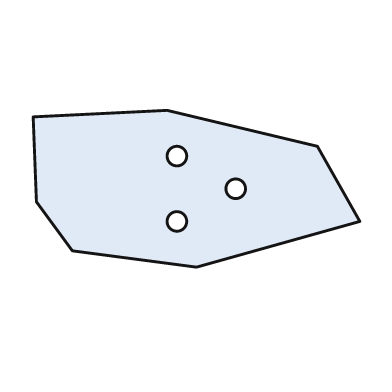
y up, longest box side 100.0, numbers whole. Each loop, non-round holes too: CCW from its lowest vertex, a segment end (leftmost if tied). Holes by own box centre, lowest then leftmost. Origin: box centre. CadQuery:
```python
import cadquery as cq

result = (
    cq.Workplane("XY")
    .moveTo(0.0, -24.0)
    .lineTo(50.0, -10.0)
    .lineTo(37.0, 13.0)
    .lineTo(-9.0, 24.0)
    .lineTo(-50.0, 22.0)
    .lineTo(-49.0, -4.0)
    .lineTo(-38.0, -19.0)
    .close()
    .moveTo(-6.0, -10.0)
    .circle(3.0)
    .moveTo(12.0, 0.0)
    .circle(3.0)
    .moveTo(-6.0, 10.0)
    .circle(3.0)
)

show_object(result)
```